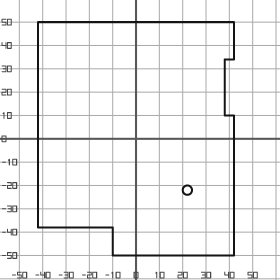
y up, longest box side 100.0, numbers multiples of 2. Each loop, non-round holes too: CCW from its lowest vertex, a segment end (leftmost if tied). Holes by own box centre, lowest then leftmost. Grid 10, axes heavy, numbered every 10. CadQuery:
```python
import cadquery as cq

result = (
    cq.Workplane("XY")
    .moveTo(-10.0, -50.0)
    .lineTo(42.0, -50.0)
    .lineTo(42.0, 10.0)
    .lineTo(38.0, 10.0)
    .lineTo(38.0, 34.0)
    .lineTo(42.0, 34.0)
    .lineTo(42.0, 50.0)
    .lineTo(-42.0, 50.0)
    .lineTo(-42.0, -38.0)
    .lineTo(-10.0, -38.0)
    .close()
    .moveTo(22.0, -22.0)
    .circle(2.0)
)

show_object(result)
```